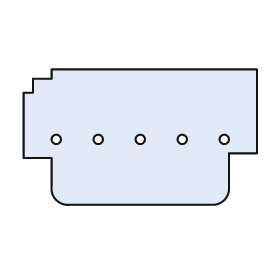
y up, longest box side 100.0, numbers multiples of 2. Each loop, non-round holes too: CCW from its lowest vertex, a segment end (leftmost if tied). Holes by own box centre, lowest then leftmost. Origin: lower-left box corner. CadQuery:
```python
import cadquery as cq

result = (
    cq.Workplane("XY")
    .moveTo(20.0, 0.0)
    .lineTo(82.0, 0.0)
    .threePointArc((86.0, 2.0), (88.0, 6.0))
    .lineTo(88.0, 22.0)
    .lineTo(100.0, 22.0)
    .lineTo(100.0, 58.0)
    .lineTo(12.0, 58.0)
    .lineTo(12.0, 54.0)
    .lineTo(4.0, 54.0)
    .lineTo(4.0, 48.0)
    .lineTo(0.0, 48.0)
    .lineTo(0.0, 20.0)
    .lineTo(12.0, 20.0)
    .lineTo(12.0, 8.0)
    .threePointArc((14.0, 2.0), (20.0, 0.0))
    .close()
    .moveTo(14.0, 28.0)
    .circle(2.0)
    .moveTo(32.0, 28.0)
    .circle(2.0)
    .moveTo(50.0, 28.0)
    .circle(2.0)
    .moveTo(68.0, 28.0)
    .circle(2.0)
    .moveTo(86.0, 28.0)
    .circle(2.0)
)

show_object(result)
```